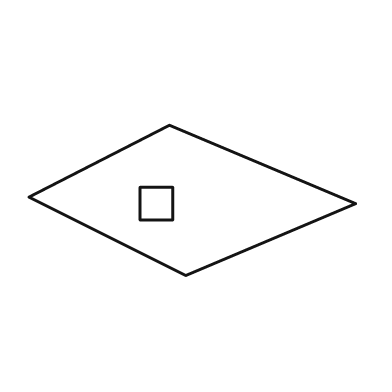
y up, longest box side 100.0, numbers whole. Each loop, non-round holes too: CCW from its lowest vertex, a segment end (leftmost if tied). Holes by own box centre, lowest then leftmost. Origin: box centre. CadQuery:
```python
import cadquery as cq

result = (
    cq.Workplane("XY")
    .moveTo(-2.0, -23.0)
    .lineTo(50.0, -1.0)
    .lineTo(-7.0, 23.0)
    .lineTo(-50.0, 1.0)
    .close()
    .moveTo(-16.0, -6.0)
    .lineTo(-6.0, -6.0)
    .lineTo(-6.0, 4.0)
    .lineTo(-16.0, 4.0)
    .close()
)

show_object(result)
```